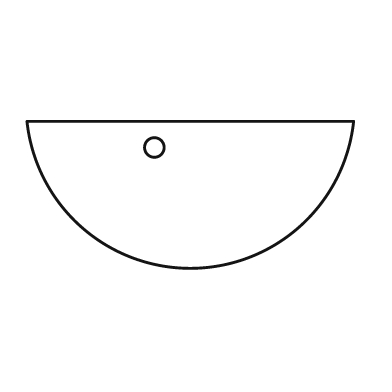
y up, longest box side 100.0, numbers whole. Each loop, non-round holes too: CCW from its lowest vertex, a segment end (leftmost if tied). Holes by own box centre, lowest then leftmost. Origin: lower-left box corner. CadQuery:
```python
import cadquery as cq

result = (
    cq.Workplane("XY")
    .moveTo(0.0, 45.0)
    .threePointArc((50.0, 0.0), (100.0, 45.0))
    .close()
    .moveTo(39.0, 37.0)
    .circle(3.0)
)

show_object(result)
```